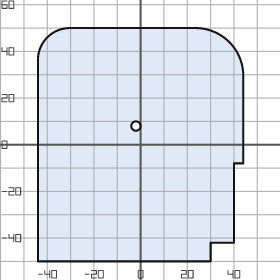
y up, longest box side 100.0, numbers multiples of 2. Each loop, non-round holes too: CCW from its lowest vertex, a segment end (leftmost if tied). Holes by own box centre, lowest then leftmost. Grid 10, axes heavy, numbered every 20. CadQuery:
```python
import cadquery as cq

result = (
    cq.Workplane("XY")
    .moveTo(-44.0, -50.0)
    .lineTo(30.0, -50.0)
    .lineTo(30.0, -42.0)
    .lineTo(40.0, -42.0)
    .lineTo(40.0, -8.0)
    .lineTo(44.0, -8.0)
    .lineTo(44.0, 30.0)
    .threePointArc((38.0, 44.0), (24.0, 50.0))
    .lineTo(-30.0, 50.0)
    .threePointArc((-40.0, 46.0), (-44.0, 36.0))
    .close()
    .moveTo(-2.0, 8.0)
    .circle(2.0)
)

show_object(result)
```